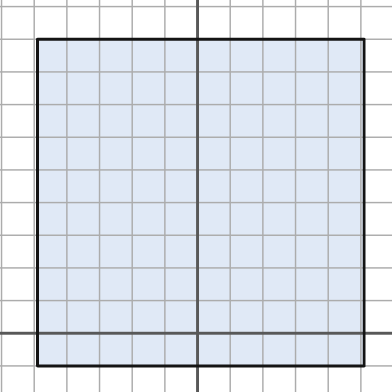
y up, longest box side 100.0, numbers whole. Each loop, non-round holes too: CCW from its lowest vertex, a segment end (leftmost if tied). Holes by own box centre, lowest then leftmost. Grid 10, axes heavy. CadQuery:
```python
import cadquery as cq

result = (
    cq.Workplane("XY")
    .moveTo(-49.0, -10.0)
    .lineTo(51.0, -10.0)
    .lineTo(51.0, 90.0)
    .lineTo(-49.0, 90.0)
    .close()
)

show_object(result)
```